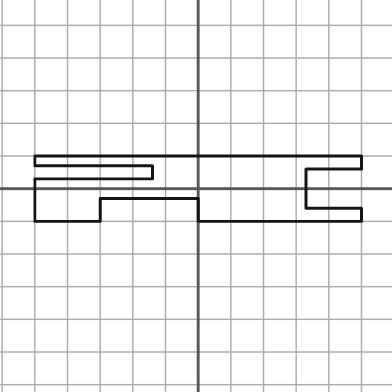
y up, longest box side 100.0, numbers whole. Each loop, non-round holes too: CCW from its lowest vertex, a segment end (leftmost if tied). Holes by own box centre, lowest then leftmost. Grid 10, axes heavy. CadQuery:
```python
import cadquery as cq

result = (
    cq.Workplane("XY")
    .moveTo(-50.0, -10.0)
    .lineTo(-30.0, -10.0)
    .lineTo(-30.0, -3.0)
    .lineTo(0.0, -3.0)
    .lineTo(0.0, -10.0)
    .lineTo(50.0, -10.0)
    .lineTo(50.0, -6.0)
    .lineTo(33.0, -6.0)
    .lineTo(33.0, 6.0)
    .lineTo(50.0, 6.0)
    .lineTo(50.0, 10.0)
    .lineTo(-50.0, 10.0)
    .lineTo(-50.0, 7.0)
    .lineTo(-14.0, 7.0)
    .lineTo(-14.0, 3.0)
    .lineTo(-50.0, 3.0)
    .close()
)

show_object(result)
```